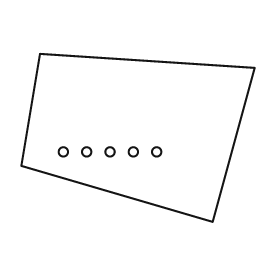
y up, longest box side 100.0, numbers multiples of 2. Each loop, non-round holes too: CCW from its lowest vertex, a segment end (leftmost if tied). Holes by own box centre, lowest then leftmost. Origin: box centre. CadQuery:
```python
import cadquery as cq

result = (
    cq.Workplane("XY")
    .moveTo(32.0, -36.0)
    .lineTo(50.0, 30.0)
    .lineTo(-42.0, 36.0)
    .lineTo(-50.0, -12.0)
    .close()
    .moveTo(-32.0, -6.0)
    .circle(2.0)
    .moveTo(-22.0, -6.0)
    .circle(2.0)
    .moveTo(-12.0, -6.0)
    .circle(2.0)
    .moveTo(-2.0, -6.0)
    .circle(2.0)
    .moveTo(8.0, -6.0)
    .circle(2.0)
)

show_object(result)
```